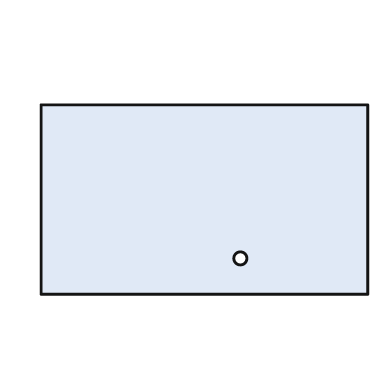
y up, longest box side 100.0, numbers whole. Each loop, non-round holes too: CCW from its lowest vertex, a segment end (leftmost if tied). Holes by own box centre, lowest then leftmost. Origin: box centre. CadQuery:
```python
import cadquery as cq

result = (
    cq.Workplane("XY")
    .moveTo(-50.0, -29.0)
    .lineTo(50.0, -29.0)
    .lineTo(50.0, 29.0)
    .lineTo(-50.0, 29.0)
    .close()
    .moveTo(11.0, -18.0)
    .circle(2.0)
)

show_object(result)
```